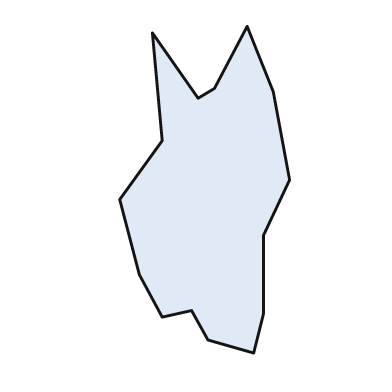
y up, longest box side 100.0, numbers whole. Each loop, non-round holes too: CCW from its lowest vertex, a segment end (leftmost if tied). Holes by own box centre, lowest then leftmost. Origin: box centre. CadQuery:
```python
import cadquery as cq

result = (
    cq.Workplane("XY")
    .moveTo(15.0, -50.0)
    .lineTo(18.0, -38.0)
    .lineTo(18.0, -14.0)
    .lineTo(26.0, 3.0)
    .lineTo(21.0, 30.0)
    .lineTo(13.0, 50.0)
    .lineTo(3.0, 31.0)
    .lineTo(-2.0, 28.0)
    .lineTo(-16.0, 48.0)
    .lineTo(-13.0, 15.0)
    .lineTo(-26.0, -3.0)
    .lineTo(-20.0, -26.0)
    .lineTo(-13.0, -39.0)
    .lineTo(-4.0, -37.0)
    .lineTo(1.0, -46.0)
    .close()
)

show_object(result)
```